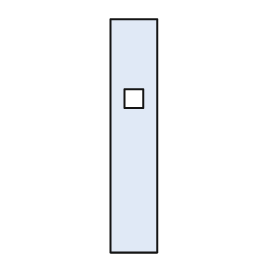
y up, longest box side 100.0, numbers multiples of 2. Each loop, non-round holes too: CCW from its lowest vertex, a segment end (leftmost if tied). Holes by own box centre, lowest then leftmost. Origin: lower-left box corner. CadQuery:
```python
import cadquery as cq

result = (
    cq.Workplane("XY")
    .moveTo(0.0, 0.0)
    .lineTo(20.0, 0.0)
    .lineTo(20.0, 100.0)
    .lineTo(0.0, 100.0)
    .close()
    .moveTo(6.0, 62.0)
    .lineTo(14.0, 62.0)
    .lineTo(14.0, 70.0)
    .lineTo(6.0, 70.0)
    .close()
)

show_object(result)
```